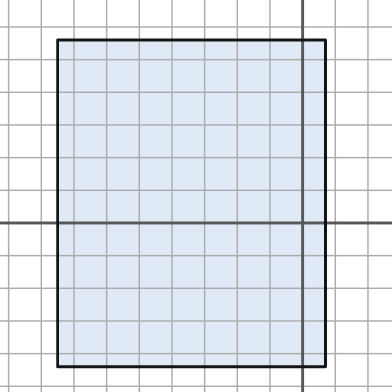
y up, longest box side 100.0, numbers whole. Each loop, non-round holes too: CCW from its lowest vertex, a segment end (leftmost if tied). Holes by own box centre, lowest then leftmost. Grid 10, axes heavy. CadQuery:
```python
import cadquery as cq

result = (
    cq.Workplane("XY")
    .moveTo(-75.0, -44.0)
    .lineTo(7.0, -44.0)
    .lineTo(7.0, 56.0)
    .lineTo(-75.0, 56.0)
    .close()
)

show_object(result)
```